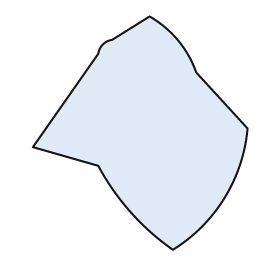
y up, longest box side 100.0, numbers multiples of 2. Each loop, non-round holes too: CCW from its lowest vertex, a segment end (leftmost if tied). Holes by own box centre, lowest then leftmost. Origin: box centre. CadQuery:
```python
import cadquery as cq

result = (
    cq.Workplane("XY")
    .moveTo(14.0, -50.0)
    .threePointArc((36.0, -28.0), (46.0, 2.0))
    .lineTo(24.0, 26.0)
    .threePointArc((16.0, 40.0), (4.0, 50.0))
    .lineTo(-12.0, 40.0)
    .threePointArc((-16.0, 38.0), (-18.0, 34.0))
    .lineTo(-46.0, -6.0)
    .lineTo(-18.0, -14.0)
    .threePointArc((-4.0, -34.0), (14.0, -50.0))
    .close()
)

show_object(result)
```